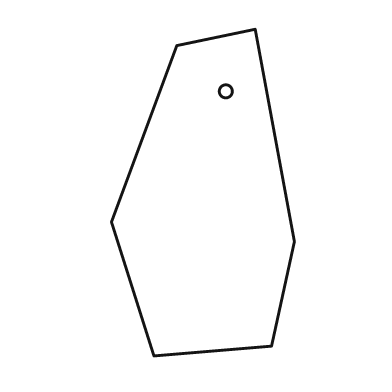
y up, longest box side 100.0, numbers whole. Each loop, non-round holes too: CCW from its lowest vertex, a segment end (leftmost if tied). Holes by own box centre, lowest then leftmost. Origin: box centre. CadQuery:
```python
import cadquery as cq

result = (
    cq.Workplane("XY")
    .moveTo(-15.0, -50.0)
    .lineTo(21.0, -47.0)
    .lineTo(28.0, -15.0)
    .lineTo(16.0, 50.0)
    .lineTo(-8.0, 45.0)
    .lineTo(-28.0, -9.0)
    .close()
    .moveTo(7.0, 31.0)
    .circle(2.0)
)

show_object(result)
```